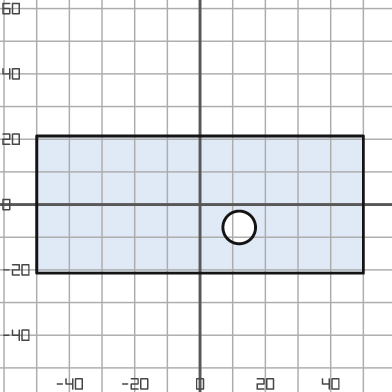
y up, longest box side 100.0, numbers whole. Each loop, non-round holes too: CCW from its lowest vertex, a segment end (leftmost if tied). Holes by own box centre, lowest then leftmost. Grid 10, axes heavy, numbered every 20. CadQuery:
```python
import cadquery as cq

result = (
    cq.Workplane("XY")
    .moveTo(-50.0, -21.0)
    .lineTo(50.0, -21.0)
    .lineTo(50.0, 21.0)
    .lineTo(-50.0, 21.0)
    .close()
    .moveTo(12.0, -7.0)
    .circle(5.0)
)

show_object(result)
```